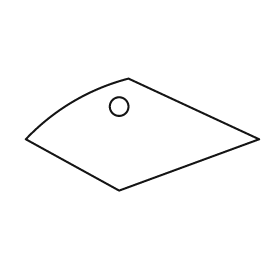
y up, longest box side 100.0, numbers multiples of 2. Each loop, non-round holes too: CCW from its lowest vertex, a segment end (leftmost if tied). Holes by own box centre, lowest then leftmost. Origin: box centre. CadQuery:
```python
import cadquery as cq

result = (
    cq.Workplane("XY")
    .moveTo(-10.0, -24.0)
    .lineTo(50.0, -2.0)
    .lineTo(-6.0, 24.0)
    .threePointArc((-30.0, 14.0), (-50.0, -2.0))
    .close()
    .moveTo(-10.0, 12.0)
    .circle(4.0)
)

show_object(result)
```